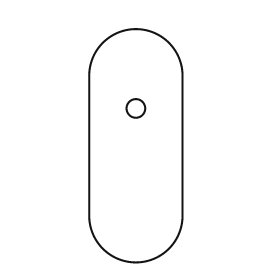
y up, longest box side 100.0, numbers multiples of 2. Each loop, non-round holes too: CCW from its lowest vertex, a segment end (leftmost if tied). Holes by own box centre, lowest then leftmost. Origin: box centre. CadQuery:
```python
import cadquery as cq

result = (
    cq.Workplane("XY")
    .moveTo(-20.0, -30.0)
    .threePointArc((0.0, -50.0), (20.0, -30.0))
    .lineTo(20.0, 30.0)
    .threePointArc((0.0, 50.0), (-20.0, 30.0))
    .close()
    .moveTo(0.0, 16.0)
    .circle(4.0)
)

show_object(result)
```